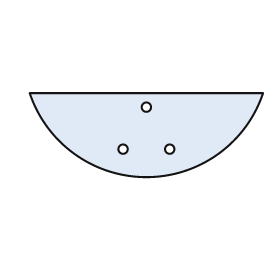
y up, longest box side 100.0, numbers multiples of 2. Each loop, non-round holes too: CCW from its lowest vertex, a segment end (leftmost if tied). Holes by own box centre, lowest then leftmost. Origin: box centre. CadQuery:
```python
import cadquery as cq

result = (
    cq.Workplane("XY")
    .moveTo(-50.0, 18.0)
    .threePointArc((0.0, -18.0), (50.0, 18.0))
    .close()
    .moveTo(-10.0, -6.0)
    .circle(2.0)
    .moveTo(10.0, -6.0)
    .circle(2.0)
    .moveTo(0.0, 12.0)
    .circle(2.0)
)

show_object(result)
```